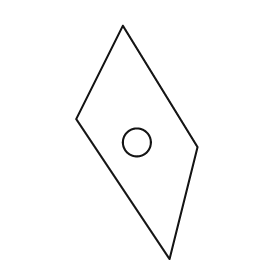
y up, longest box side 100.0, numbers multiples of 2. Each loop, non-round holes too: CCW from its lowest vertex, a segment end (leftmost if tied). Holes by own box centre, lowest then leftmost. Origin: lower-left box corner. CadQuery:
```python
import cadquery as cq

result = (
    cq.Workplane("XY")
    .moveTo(40.0, 0.0)
    .lineTo(52.0, 48.0)
    .lineTo(20.0, 100.0)
    .lineTo(0.0, 60.0)
    .close()
    .moveTo(26.0, 50.0)
    .circle(6.0)
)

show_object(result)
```